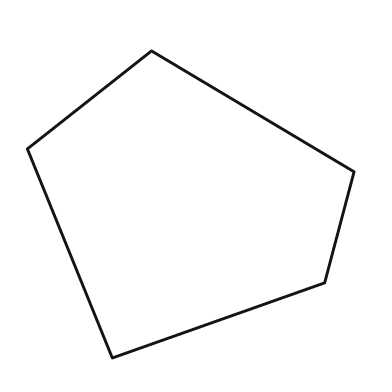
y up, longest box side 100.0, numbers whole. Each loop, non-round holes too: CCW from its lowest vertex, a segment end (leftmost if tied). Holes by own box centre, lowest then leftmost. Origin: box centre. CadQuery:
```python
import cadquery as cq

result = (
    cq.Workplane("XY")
    .moveTo(-24.0, -47.0)
    .lineTo(41.0, -24.0)
    .lineTo(50.0, 10.0)
    .lineTo(-12.0, 47.0)
    .lineTo(-50.0, 17.0)
    .close()
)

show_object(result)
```